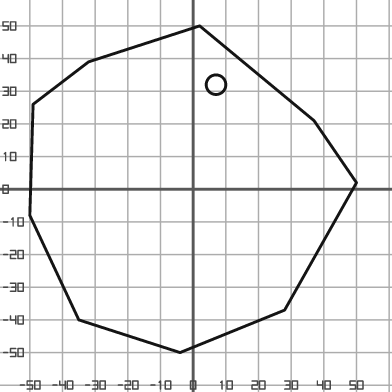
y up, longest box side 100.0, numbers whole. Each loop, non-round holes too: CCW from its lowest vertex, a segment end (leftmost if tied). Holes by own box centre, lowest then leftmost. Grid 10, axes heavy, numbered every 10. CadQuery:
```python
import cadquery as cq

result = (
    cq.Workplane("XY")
    .moveTo(-4.0, -50.0)
    .lineTo(28.0, -37.0)
    .lineTo(50.0, 2.0)
    .lineTo(37.0, 21.0)
    .lineTo(2.0, 50.0)
    .lineTo(-32.0, 39.0)
    .lineTo(-49.0, 26.0)
    .lineTo(-50.0, -8.0)
    .lineTo(-35.0, -40.0)
    .close()
    .moveTo(7.0, 32.0)
    .circle(3.0)
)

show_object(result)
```